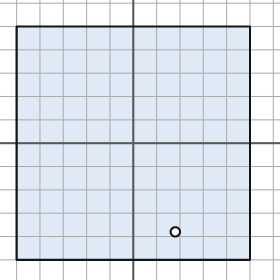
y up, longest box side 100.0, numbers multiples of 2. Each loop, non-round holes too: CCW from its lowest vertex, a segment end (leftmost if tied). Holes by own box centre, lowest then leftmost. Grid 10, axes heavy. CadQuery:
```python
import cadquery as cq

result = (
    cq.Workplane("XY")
    .moveTo(-50.0, -50.0)
    .lineTo(50.0, -50.0)
    .lineTo(50.0, 50.0)
    .lineTo(-50.0, 50.0)
    .close()
    .moveTo(18.0, -38.0)
    .circle(2.0)
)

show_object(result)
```